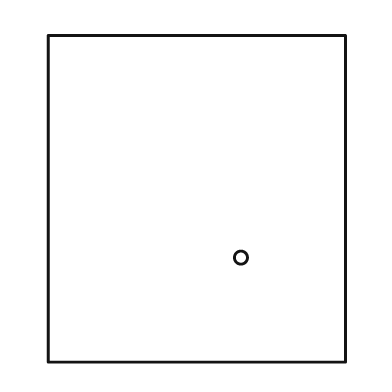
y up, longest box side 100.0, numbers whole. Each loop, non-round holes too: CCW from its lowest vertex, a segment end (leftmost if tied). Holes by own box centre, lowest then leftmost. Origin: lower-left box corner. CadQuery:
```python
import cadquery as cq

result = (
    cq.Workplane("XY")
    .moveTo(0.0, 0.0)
    .lineTo(91.0, 0.0)
    .lineTo(91.0, 100.0)
    .lineTo(0.0, 100.0)
    .close()
    .moveTo(59.0, 32.0)
    .circle(2.0)
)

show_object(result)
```